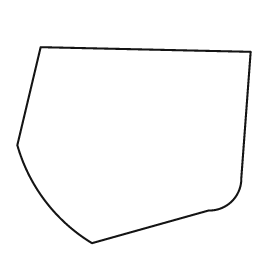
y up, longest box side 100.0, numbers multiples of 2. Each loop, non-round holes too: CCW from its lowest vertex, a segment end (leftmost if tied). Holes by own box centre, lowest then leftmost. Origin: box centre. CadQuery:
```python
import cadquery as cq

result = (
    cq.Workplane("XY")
    .moveTo(-18.0, -42.0)
    .lineTo(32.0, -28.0)
    .threePointArc((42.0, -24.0), (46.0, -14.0))
    .lineTo(50.0, 40.0)
    .lineTo(-40.0, 42.0)
    .lineTo(-50.0, 0.0)
    .threePointArc((-38.0, -24.0), (-18.0, -42.0))
    .close()
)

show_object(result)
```